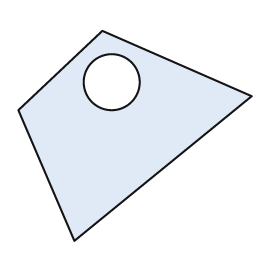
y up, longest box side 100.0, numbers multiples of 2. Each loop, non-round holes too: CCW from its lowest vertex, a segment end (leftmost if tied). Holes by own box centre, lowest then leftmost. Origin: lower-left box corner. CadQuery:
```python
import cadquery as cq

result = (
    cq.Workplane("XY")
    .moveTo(24.0, 0.0)
    .lineTo(100.0, 62.0)
    .lineTo(36.0, 90.0)
    .lineTo(0.0, 56.0)
    .close()
    .moveTo(40.0, 68.0)
    .circle(12.0)
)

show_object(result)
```